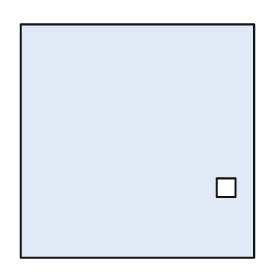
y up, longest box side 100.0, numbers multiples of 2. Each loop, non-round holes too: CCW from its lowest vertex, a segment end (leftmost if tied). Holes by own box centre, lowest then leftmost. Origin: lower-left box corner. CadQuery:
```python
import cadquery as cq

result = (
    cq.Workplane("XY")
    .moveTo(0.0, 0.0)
    .lineTo(100.0, 0.0)
    .lineTo(100.0, 100.0)
    .lineTo(0.0, 100.0)
    .close()
    .moveTo(84.0, 26.0)
    .lineTo(92.0, 26.0)
    .lineTo(92.0, 34.0)
    .lineTo(84.0, 34.0)
    .close()
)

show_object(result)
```